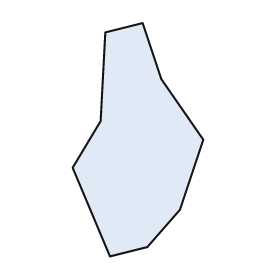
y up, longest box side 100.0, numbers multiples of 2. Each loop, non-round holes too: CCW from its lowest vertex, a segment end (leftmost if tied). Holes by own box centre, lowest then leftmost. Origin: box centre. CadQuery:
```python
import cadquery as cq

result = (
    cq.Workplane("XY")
    .moveTo(-12.0, -50.0)
    .lineTo(4.0, -46.0)
    .lineTo(18.0, -30.0)
    .lineTo(28.0, 0.0)
    .lineTo(10.0, 26.0)
    .lineTo(2.0, 50.0)
    .lineTo(-14.0, 46.0)
    .lineTo(-16.0, 8.0)
    .lineTo(-28.0, -12.0)
    .close()
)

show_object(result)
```